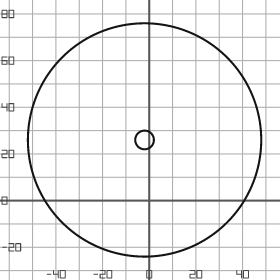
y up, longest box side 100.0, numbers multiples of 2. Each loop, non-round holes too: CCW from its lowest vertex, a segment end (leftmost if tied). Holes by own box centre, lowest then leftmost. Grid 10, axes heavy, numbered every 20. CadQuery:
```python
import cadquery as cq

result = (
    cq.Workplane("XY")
    .moveTo(-2.0, 26.0)
    .circle(50.0)
    .moveTo(-2.0, 26.0)
    .circle(4.0)
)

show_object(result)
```